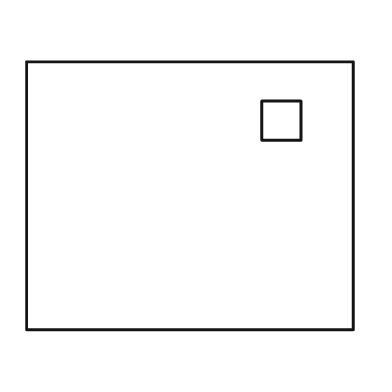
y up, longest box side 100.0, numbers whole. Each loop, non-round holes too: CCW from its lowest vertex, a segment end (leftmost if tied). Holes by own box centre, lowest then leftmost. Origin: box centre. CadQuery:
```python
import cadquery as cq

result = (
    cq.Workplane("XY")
    .moveTo(-50.0, -41.0)
    .lineTo(50.0, -41.0)
    .lineTo(50.0, 41.0)
    .lineTo(-50.0, 41.0)
    .close()
    .moveTo(22.0, 17.0)
    .lineTo(34.0, 17.0)
    .lineTo(34.0, 29.0)
    .lineTo(22.0, 29.0)
    .close()
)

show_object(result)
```